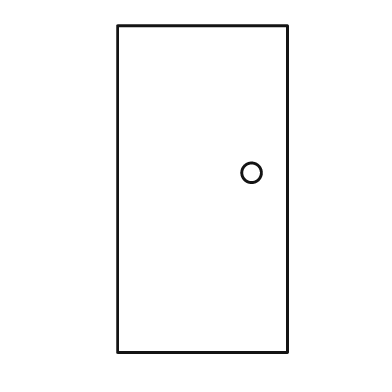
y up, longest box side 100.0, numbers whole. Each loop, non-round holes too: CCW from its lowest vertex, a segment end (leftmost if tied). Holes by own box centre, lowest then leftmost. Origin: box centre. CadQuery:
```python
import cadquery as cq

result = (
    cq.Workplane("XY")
    .moveTo(-26.0, -50.0)
    .lineTo(26.0, -50.0)
    .lineTo(26.0, 50.0)
    .lineTo(-26.0, 50.0)
    .close()
    .moveTo(15.0, 5.0)
    .circle(3.0)
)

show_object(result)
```